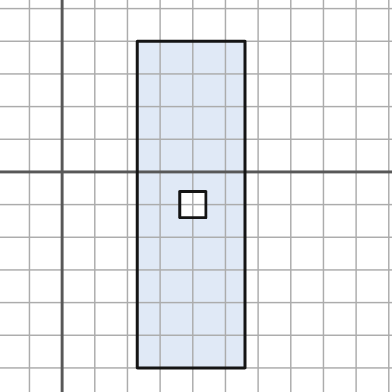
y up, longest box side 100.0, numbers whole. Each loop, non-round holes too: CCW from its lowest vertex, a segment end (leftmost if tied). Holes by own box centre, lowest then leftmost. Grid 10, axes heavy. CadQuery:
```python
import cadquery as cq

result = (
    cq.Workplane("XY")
    .moveTo(23.0, -60.0)
    .lineTo(56.0, -60.0)
    .lineTo(56.0, 40.0)
    .lineTo(23.0, 40.0)
    .close()
    .moveTo(36.0, -14.0)
    .lineTo(44.0, -14.0)
    .lineTo(44.0, -6.0)
    .lineTo(36.0, -6.0)
    .close()
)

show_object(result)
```